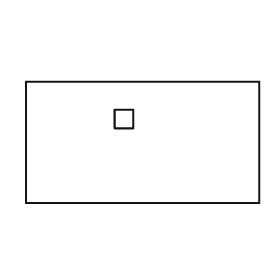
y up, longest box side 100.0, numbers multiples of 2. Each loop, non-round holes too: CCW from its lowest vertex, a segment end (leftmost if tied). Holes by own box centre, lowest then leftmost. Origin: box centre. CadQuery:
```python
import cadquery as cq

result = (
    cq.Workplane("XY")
    .moveTo(-50.0, -26.0)
    .lineTo(50.0, -26.0)
    .lineTo(50.0, 26.0)
    .lineTo(-50.0, 26.0)
    .close()
    .moveTo(-12.0, 6.0)
    .lineTo(-4.0, 6.0)
    .lineTo(-4.0, 14.0)
    .lineTo(-12.0, 14.0)
    .close()
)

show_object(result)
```